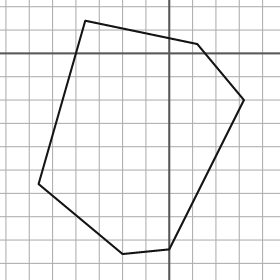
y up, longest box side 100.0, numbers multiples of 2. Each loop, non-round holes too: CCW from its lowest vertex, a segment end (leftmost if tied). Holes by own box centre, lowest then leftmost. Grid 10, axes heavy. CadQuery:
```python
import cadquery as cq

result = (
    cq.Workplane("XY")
    .moveTo(-20.0, -86.0)
    .lineTo(0.0, -84.0)
    .lineTo(32.0, -20.0)
    .lineTo(12.0, 4.0)
    .lineTo(-36.0, 14.0)
    .lineTo(-56.0, -56.0)
    .close()
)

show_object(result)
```